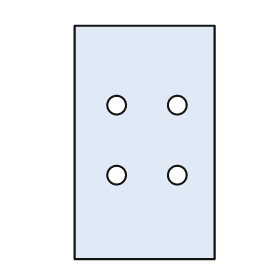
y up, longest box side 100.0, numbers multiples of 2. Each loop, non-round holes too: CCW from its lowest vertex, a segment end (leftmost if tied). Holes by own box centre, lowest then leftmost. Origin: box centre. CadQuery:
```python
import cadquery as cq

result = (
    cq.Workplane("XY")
    .moveTo(-30.0, -50.0)
    .lineTo(30.0, -50.0)
    .lineTo(30.0, 50.0)
    .lineTo(-30.0, 50.0)
    .close()
    .moveTo(-12.0, -14.0)
    .circle(4.0)
    .moveTo(14.0, -14.0)
    .circle(4.0)
    .moveTo(-12.0, 16.0)
    .circle(4.0)
    .moveTo(14.0, 16.0)
    .circle(4.0)
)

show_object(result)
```